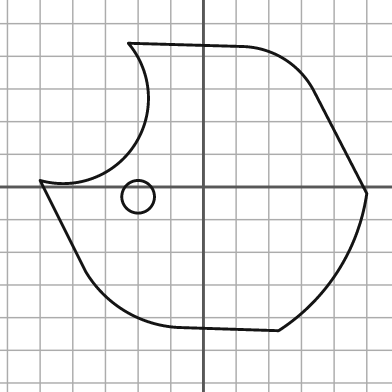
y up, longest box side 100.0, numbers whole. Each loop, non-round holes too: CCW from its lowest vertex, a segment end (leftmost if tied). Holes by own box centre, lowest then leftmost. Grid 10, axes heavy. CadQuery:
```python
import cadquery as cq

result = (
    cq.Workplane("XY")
    .moveTo(23.0, -44.0)
    .threePointArc((41.0, -26.0), (50.0, -2.0))
    .lineTo(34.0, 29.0)
    .threePointArc((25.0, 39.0), (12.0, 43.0))
    .lineTo(-23.0, 44.0)
    .threePointArc((-21.0, 13.0), (-50.0, 2.0))
    .lineTo(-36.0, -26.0)
    .threePointArc((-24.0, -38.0), (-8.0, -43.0))
    .close()
    .moveTo(-20.0, -3.0)
    .circle(5.0)
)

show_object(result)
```